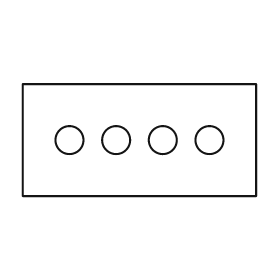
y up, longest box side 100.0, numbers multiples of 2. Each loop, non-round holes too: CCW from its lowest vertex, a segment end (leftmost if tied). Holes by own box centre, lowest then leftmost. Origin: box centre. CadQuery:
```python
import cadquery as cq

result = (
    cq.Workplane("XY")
    .moveTo(-50.0, -24.0)
    .lineTo(50.0, -24.0)
    .lineTo(50.0, 24.0)
    .lineTo(-50.0, 24.0)
    .close()
    .moveTo(-30.0, 0.0)
    .circle(6.0)
    .moveTo(-10.0, 0.0)
    .circle(6.0)
    .moveTo(10.0, 0.0)
    .circle(6.0)
    .moveTo(30.0, 0.0)
    .circle(6.0)
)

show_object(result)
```